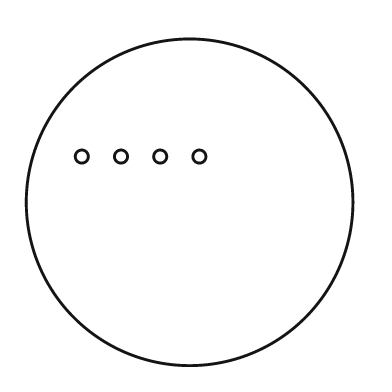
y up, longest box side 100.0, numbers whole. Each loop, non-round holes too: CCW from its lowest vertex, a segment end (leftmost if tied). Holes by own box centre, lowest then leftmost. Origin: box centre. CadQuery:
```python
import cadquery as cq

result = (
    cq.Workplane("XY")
    .moveTo(0.0, 0.0)
    .circle(50.0)
    .moveTo(-33.0, 14.0)
    .circle(2.0)
    .moveTo(-21.0, 14.0)
    .circle(2.0)
    .moveTo(-9.0, 14.0)
    .circle(2.0)
    .moveTo(3.0, 14.0)
    .circle(2.0)
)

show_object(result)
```